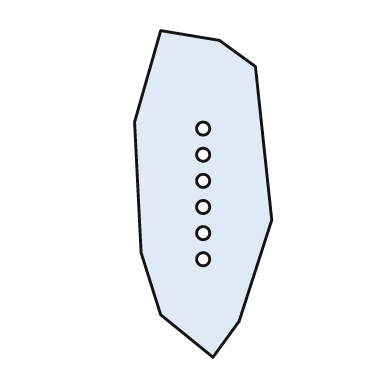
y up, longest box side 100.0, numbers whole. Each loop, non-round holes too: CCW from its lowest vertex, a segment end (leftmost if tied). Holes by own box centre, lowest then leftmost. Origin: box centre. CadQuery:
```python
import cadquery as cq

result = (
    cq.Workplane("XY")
    .moveTo(3.0, -50.0)
    .lineTo(11.0, -39.0)
    .lineTo(21.0, -8.0)
    .lineTo(16.0, 39.0)
    .lineTo(5.0, 47.0)
    .lineTo(-13.0, 50.0)
    .lineTo(-21.0, 22.0)
    .lineTo(-19.0, -18.0)
    .lineTo(-13.0, -37.0)
    .close()
    .moveTo(0.0, -20.0)
    .circle(2.0)
    .moveTo(0.0, -12.0)
    .circle(2.0)
    .moveTo(0.0, -4.0)
    .circle(2.0)
    .moveTo(0.0, 4.0)
    .circle(2.0)
    .moveTo(0.0, 12.0)
    .circle(2.0)
    .moveTo(0.0, 20.0)
    .circle(2.0)
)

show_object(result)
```